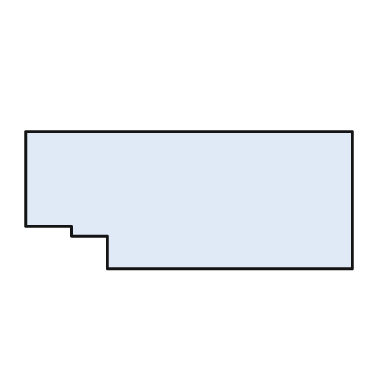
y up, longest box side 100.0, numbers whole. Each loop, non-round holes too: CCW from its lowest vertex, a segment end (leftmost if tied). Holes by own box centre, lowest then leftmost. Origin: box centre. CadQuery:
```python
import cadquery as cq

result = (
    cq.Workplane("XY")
    .moveTo(-25.0, -21.0)
    .lineTo(50.0, -21.0)
    .lineTo(50.0, 21.0)
    .lineTo(-50.0, 21.0)
    .lineTo(-50.0, -8.0)
    .lineTo(-36.0, -8.0)
    .lineTo(-36.0, -11.0)
    .lineTo(-25.0, -11.0)
    .close()
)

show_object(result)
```